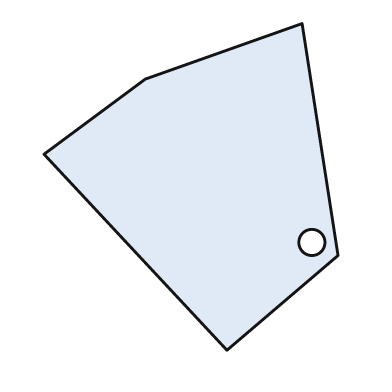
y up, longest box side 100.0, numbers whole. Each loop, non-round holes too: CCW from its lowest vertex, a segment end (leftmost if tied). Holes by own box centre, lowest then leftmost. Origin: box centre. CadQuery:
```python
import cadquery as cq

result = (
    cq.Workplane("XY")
    .moveTo(11.0, -50.0)
    .lineTo(45.0, -21.0)
    .lineTo(34.0, 50.0)
    .lineTo(-14.0, 33.0)
    .lineTo(-45.0, 10.0)
    .close()
    .moveTo(37.0, -17.0)
    .circle(4.0)
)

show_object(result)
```